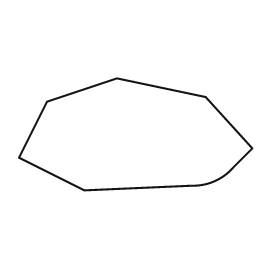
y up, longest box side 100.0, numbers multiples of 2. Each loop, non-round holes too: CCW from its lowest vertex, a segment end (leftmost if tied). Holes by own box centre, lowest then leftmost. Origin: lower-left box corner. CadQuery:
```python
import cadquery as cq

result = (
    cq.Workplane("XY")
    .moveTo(28.0, 0.0)
    .lineTo(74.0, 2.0)
    .threePointArc((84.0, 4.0), (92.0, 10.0))
    .lineTo(100.0, 18.0)
    .lineTo(80.0, 40.0)
    .lineTo(42.0, 48.0)
    .lineTo(12.0, 38.0)
    .lineTo(0.0, 14.0)
    .close()
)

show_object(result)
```